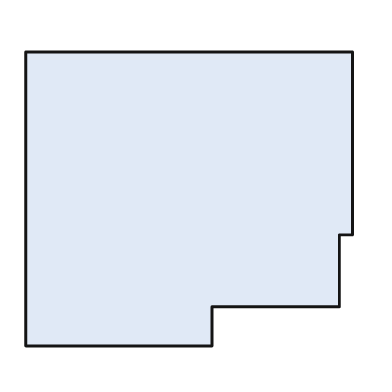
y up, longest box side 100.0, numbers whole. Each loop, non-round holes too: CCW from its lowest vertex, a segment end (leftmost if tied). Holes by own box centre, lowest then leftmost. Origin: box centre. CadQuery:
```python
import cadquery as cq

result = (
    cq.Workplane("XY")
    .moveTo(-50.0, -45.0)
    .lineTo(7.0, -45.0)
    .lineTo(7.0, -33.0)
    .lineTo(46.0, -33.0)
    .lineTo(46.0, -11.0)
    .lineTo(50.0, -11.0)
    .lineTo(50.0, 45.0)
    .lineTo(-50.0, 45.0)
    .close()
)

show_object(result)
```